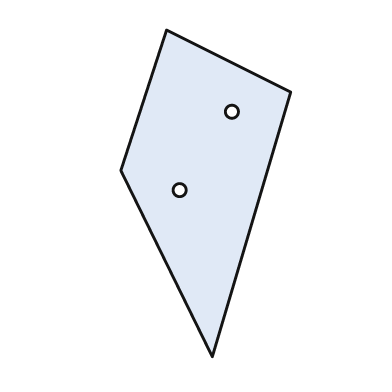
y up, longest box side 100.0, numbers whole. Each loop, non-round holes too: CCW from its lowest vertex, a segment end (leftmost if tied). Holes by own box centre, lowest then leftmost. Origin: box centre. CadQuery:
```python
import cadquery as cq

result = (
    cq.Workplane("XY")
    .moveTo(2.0, -50.0)
    .lineTo(26.0, 31.0)
    .lineTo(-12.0, 50.0)
    .lineTo(-26.0, 7.0)
    .close()
    .moveTo(-8.0, 1.0)
    .circle(2.0)
    .moveTo(8.0, 25.0)
    .circle(2.0)
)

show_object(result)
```